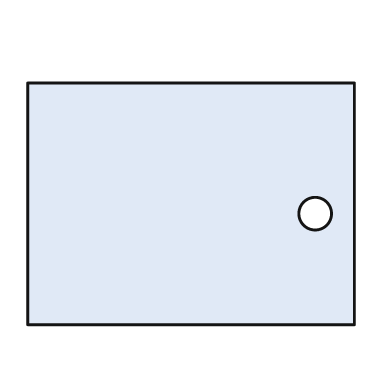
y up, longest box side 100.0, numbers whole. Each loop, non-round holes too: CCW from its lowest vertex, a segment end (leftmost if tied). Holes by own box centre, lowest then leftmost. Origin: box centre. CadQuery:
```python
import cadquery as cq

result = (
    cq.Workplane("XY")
    .moveTo(-50.0, -37.0)
    .lineTo(50.0, -37.0)
    .lineTo(50.0, 37.0)
    .lineTo(-50.0, 37.0)
    .close()
    .moveTo(38.0, -3.0)
    .circle(5.0)
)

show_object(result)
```